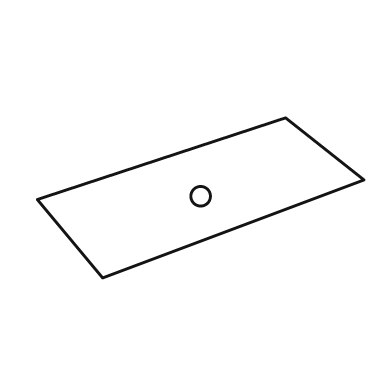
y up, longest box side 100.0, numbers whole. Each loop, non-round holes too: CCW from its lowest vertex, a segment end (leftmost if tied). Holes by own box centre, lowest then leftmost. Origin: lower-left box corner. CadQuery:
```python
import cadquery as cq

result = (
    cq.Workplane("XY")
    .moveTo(20.0, 0.0)
    .lineTo(100.0, 30.0)
    .lineTo(76.0, 49.0)
    .lineTo(0.0, 24.0)
    .close()
    .moveTo(50.0, 25.0)
    .circle(3.0)
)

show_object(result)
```